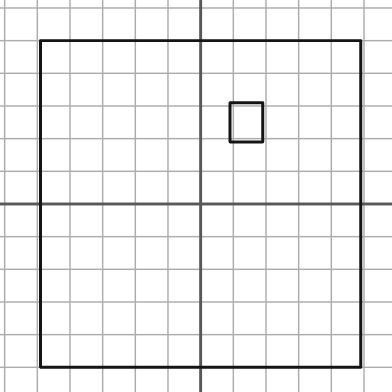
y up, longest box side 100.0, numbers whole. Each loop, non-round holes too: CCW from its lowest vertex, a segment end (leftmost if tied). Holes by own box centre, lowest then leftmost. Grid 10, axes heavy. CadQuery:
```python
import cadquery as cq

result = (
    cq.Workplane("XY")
    .moveTo(-49.0, -50.0)
    .lineTo(49.0, -50.0)
    .lineTo(49.0, 50.0)
    .lineTo(-49.0, 50.0)
    .close()
    .moveTo(9.0, 19.0)
    .lineTo(19.0, 19.0)
    .lineTo(19.0, 31.0)
    .lineTo(9.0, 31.0)
    .close()
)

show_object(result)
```